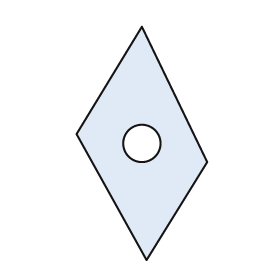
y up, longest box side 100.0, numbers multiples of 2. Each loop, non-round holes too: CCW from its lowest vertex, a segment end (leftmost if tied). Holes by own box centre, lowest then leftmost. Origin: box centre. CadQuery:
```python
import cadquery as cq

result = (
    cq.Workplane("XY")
    .moveTo(2.0, -50.0)
    .lineTo(28.0, -8.0)
    .lineTo(0.0, 50.0)
    .lineTo(-28.0, 4.0)
    .close()
    .moveTo(0.0, 0.0)
    .circle(8.0)
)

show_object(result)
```